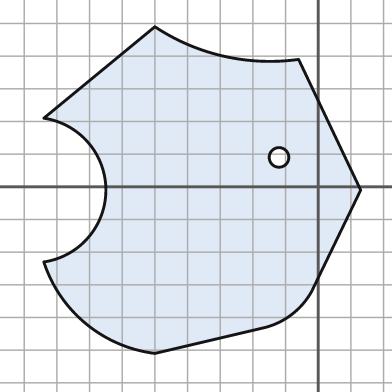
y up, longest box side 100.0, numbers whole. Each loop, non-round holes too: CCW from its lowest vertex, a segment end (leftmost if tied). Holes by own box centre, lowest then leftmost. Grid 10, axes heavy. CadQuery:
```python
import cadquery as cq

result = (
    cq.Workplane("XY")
    .moveTo(-50.0, -51.0)
    .lineTo(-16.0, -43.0)
    .threePointArc((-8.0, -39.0), (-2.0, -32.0))
    .lineTo(13.0, -1.0)
    .lineTo(-6.0, 39.0)
    .threePointArc((-29.0, 40.0), (-50.0, 49.0))
    .lineTo(-84.0, 21.0)
    .threePointArc((-65.0, -1.0), (-84.0, -23.0))
    .threePointArc((-71.0, -42.0), (-50.0, -51.0))
    .close()
    .moveTo(-12.0, 9.0)
    .circle(3.0)
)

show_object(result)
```